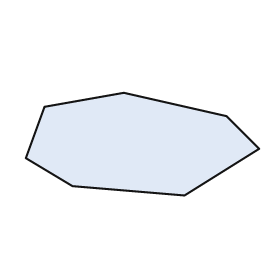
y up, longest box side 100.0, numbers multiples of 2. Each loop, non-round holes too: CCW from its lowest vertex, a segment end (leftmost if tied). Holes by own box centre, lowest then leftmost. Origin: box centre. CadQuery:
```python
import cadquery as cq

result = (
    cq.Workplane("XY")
    .moveTo(18.0, -22.0)
    .lineTo(50.0, -2.0)
    .lineTo(36.0, 12.0)
    .lineTo(-8.0, 22.0)
    .lineTo(-42.0, 16.0)
    .lineTo(-50.0, -6.0)
    .lineTo(-30.0, -18.0)
    .close()
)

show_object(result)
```